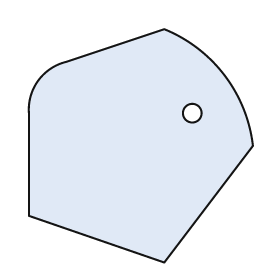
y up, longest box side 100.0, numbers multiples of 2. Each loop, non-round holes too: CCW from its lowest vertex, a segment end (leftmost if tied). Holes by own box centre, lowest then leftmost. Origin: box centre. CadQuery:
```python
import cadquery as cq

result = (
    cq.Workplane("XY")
    .moveTo(10.0, -50.0)
    .lineTo(48.0, 0.0)
    .threePointArc((36.0, 30.0), (10.0, 50.0))
    .lineTo(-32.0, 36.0)
    .threePointArc((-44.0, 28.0), (-48.0, 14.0))
    .lineTo(-48.0, -30.0)
    .close()
    .moveTo(22.0, 14.0)
    .circle(4.0)
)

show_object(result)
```